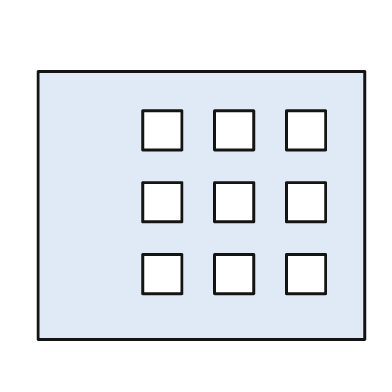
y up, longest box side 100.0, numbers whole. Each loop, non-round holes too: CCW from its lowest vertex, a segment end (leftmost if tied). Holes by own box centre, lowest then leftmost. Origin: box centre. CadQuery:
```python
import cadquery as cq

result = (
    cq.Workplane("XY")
    .moveTo(-50.0, -41.0)
    .lineTo(50.0, -41.0)
    .lineTo(50.0, 41.0)
    .lineTo(-50.0, 41.0)
    .close()
    .moveTo(-18.0, -27.0)
    .lineTo(-6.0, -27.0)
    .lineTo(-6.0, -15.0)
    .lineTo(-18.0, -15.0)
    .close()
    .moveTo(4.0, -27.0)
    .lineTo(16.0, -27.0)
    .lineTo(16.0, -15.0)
    .lineTo(4.0, -15.0)
    .close()
    .moveTo(26.0, -27.0)
    .lineTo(38.0, -27.0)
    .lineTo(38.0, -15.0)
    .lineTo(26.0, -15.0)
    .close()
    .moveTo(-18.0, -5.0)
    .lineTo(-6.0, -5.0)
    .lineTo(-6.0, 7.0)
    .lineTo(-18.0, 7.0)
    .close()
    .moveTo(4.0, -5.0)
    .lineTo(16.0, -5.0)
    .lineTo(16.0, 7.0)
    .lineTo(4.0, 7.0)
    .close()
    .moveTo(26.0, -5.0)
    .lineTo(38.0, -5.0)
    .lineTo(38.0, 7.0)
    .lineTo(26.0, 7.0)
    .close()
    .moveTo(-18.0, 17.0)
    .lineTo(-6.0, 17.0)
    .lineTo(-6.0, 29.0)
    .lineTo(-18.0, 29.0)
    .close()
    .moveTo(4.0, 17.0)
    .lineTo(16.0, 17.0)
    .lineTo(16.0, 29.0)
    .lineTo(4.0, 29.0)
    .close()
    .moveTo(26.0, 17.0)
    .lineTo(38.0, 17.0)
    .lineTo(38.0, 29.0)
    .lineTo(26.0, 29.0)
    .close()
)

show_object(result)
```